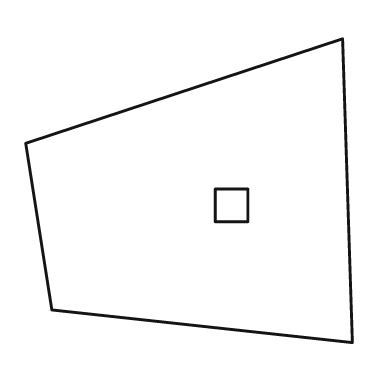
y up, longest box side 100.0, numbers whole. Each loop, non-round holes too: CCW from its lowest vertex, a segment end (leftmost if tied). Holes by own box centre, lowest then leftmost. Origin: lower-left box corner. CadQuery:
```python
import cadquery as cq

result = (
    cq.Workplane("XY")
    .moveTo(100.0, 0.0)
    .lineTo(97.0, 93.0)
    .lineTo(0.0, 61.0)
    .lineTo(8.0, 10.0)
    .close()
    .moveTo(58.0, 37.0)
    .lineTo(68.0, 37.0)
    .lineTo(68.0, 47.0)
    .lineTo(58.0, 47.0)
    .close()
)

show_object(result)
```